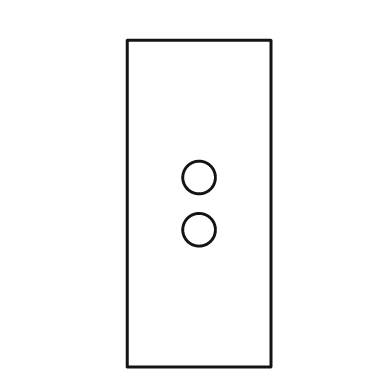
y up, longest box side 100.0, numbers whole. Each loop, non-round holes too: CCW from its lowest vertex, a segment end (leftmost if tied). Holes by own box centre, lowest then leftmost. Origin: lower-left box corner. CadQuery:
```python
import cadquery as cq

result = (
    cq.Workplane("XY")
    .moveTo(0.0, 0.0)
    .lineTo(44.0, 0.0)
    .lineTo(44.0, 100.0)
    .lineTo(0.0, 100.0)
    .close()
    .moveTo(22.0, 42.0)
    .circle(5.0)
    .moveTo(22.0, 58.0)
    .circle(5.0)
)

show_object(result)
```